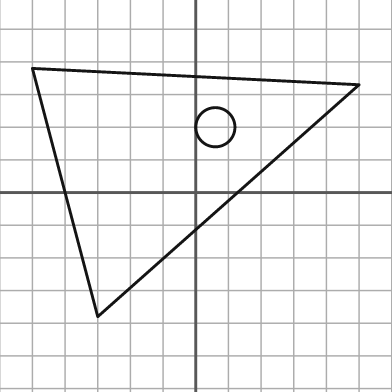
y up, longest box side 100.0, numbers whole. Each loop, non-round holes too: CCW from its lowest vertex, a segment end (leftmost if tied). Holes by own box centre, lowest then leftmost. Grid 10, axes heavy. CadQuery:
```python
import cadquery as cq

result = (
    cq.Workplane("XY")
    .moveTo(-30.0, -38.0)
    .lineTo(50.0, 33.0)
    .lineTo(-50.0, 38.0)
    .close()
    .moveTo(6.0, 20.0)
    .circle(6.0)
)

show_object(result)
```